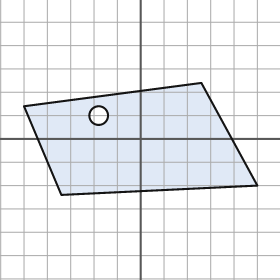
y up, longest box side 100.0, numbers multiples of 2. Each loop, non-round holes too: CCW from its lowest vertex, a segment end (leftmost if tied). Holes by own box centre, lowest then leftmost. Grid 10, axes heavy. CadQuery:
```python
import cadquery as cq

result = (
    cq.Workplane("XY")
    .moveTo(-34.0, -24.0)
    .lineTo(50.0, -20.0)
    .lineTo(26.0, 24.0)
    .lineTo(-50.0, 14.0)
    .close()
    .moveTo(-18.0, 10.0)
    .circle(4.0)
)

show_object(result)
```